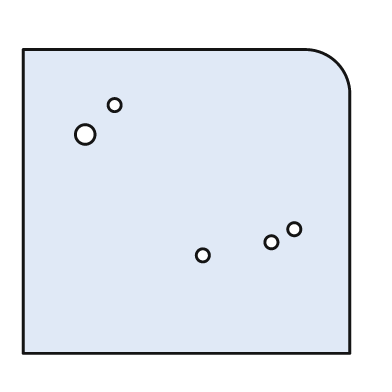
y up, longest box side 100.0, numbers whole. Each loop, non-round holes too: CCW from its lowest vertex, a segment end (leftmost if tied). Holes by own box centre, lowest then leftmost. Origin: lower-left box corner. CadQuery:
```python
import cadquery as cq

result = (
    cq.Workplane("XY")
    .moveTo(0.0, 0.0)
    .lineTo(100.0, 0.0)
    .lineTo(100.0, 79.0)
    .threePointArc((96.0, 89.0), (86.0, 93.0))
    .lineTo(0.0, 93.0)
    .close()
    .moveTo(55.0, 30.0)
    .circle(2.0)
    .moveTo(76.0, 34.0)
    .circle(2.0)
    .moveTo(83.0, 38.0)
    .circle(2.0)
    .moveTo(19.0, 67.0)
    .circle(3.0)
    .moveTo(28.0, 76.0)
    .circle(2.0)
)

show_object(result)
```